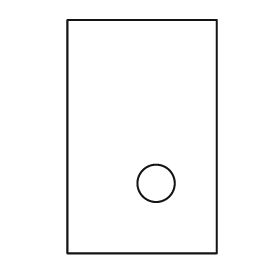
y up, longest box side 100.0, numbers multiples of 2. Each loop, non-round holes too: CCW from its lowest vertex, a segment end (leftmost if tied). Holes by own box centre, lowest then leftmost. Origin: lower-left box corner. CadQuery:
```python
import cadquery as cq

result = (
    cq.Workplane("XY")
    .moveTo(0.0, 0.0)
    .lineTo(64.0, 0.0)
    .lineTo(64.0, 100.0)
    .lineTo(0.0, 100.0)
    .close()
    .moveTo(38.0, 30.0)
    .circle(8.0)
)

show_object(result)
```